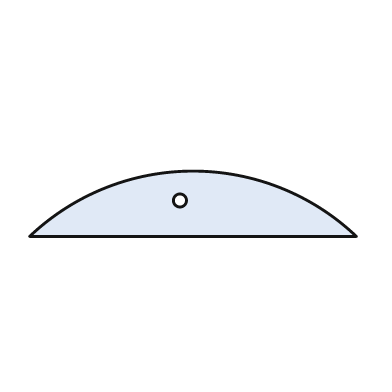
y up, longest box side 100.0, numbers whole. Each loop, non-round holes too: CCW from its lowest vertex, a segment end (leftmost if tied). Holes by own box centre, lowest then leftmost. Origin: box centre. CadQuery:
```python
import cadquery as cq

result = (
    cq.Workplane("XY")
    .moveTo(-50.0, -10.0)
    .lineTo(50.0, -10.0)
    .threePointArc((0.0, 10.0), (-50.0, -10.0))
    .close()
    .moveTo(-4.0, 1.0)
    .circle(2.0)
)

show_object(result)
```